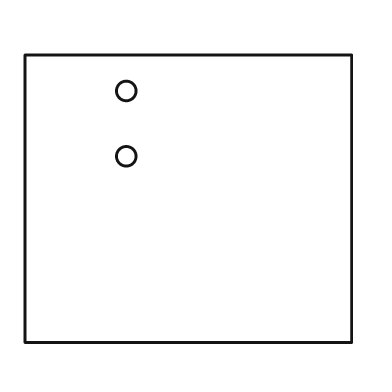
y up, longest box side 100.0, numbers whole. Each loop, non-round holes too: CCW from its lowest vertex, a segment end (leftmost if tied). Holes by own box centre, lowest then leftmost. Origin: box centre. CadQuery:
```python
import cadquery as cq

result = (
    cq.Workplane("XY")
    .moveTo(-50.0, -44.0)
    .lineTo(50.0, -44.0)
    .lineTo(50.0, 44.0)
    .lineTo(-50.0, 44.0)
    .close()
    .moveTo(-19.0, 13.0)
    .circle(3.0)
    .moveTo(-19.0, 33.0)
    .circle(3.0)
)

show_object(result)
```